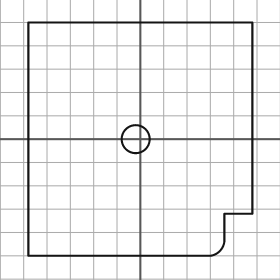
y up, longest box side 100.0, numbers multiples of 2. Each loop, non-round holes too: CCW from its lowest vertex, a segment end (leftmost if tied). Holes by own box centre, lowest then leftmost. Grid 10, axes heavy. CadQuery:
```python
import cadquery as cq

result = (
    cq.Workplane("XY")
    .moveTo(-48.0, -50.0)
    .lineTo(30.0, -50.0)
    .threePointArc((34.0, -48.0), (36.0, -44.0))
    .lineTo(36.0, -32.0)
    .lineTo(48.0, -32.0)
    .lineTo(48.0, 50.0)
    .lineTo(-48.0, 50.0)
    .close()
    .moveTo(-2.0, 0.0)
    .circle(6.0)
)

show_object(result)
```